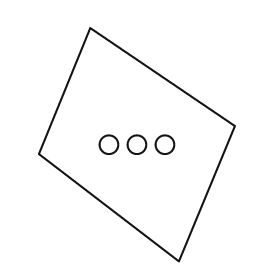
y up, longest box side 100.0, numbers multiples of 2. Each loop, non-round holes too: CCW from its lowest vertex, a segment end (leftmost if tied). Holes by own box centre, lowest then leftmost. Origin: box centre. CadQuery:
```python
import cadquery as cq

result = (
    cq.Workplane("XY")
    .moveTo(18.0, -50.0)
    .lineTo(42.0, 8.0)
    .lineTo(-20.0, 50.0)
    .lineTo(-42.0, -4.0)
    .close()
    .moveTo(-12.0, 0.0)
    .circle(4.0)
    .moveTo(0.0, 0.0)
    .circle(4.0)
    .moveTo(12.0, 0.0)
    .circle(4.0)
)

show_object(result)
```